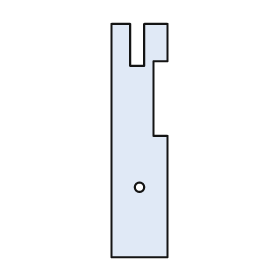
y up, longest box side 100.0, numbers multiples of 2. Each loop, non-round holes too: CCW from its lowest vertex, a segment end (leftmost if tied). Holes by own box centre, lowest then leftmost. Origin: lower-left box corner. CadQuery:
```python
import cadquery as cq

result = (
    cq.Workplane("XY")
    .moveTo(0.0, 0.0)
    .lineTo(24.0, 0.0)
    .lineTo(24.0, 52.0)
    .lineTo(18.0, 52.0)
    .lineTo(18.0, 84.0)
    .lineTo(24.0, 84.0)
    .lineTo(24.0, 100.0)
    .lineTo(14.0, 100.0)
    .lineTo(14.0, 82.0)
    .lineTo(8.0, 82.0)
    .lineTo(8.0, 100.0)
    .lineTo(0.0, 100.0)
    .close()
    .moveTo(12.0, 30.0)
    .circle(2.0)
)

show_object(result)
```